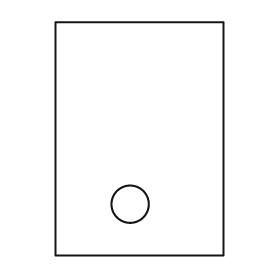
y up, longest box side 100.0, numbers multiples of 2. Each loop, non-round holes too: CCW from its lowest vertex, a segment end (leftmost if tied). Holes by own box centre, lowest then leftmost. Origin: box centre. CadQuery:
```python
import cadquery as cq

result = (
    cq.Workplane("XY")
    .moveTo(-36.0, -50.0)
    .lineTo(36.0, -50.0)
    .lineTo(36.0, 50.0)
    .lineTo(-36.0, 50.0)
    .close()
    .moveTo(-4.0, -28.0)
    .circle(8.0)
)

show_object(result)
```